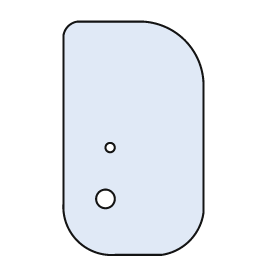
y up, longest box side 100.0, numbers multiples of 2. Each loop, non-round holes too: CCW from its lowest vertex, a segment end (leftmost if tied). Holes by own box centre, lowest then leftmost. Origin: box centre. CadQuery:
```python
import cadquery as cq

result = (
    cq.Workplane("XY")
    .moveTo(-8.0, -50.0)
    .lineTo(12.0, -50.0)
    .threePointArc((24.0, -44.0), (30.0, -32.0))
    .lineTo(30.0, 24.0)
    .threePointArc((22.0, 42.0), (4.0, 50.0))
    .lineTo(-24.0, 50.0)
    .threePointArc((-28.0, 48.0), (-30.0, 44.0))
    .lineTo(-30.0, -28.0)
    .threePointArc((-24.0, -44.0), (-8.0, -50.0))
    .close()
    .moveTo(-12.0, -26.0)
    .circle(4.0)
    .moveTo(-10.0, -4.0)
    .circle(2.0)
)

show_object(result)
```